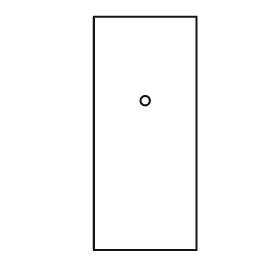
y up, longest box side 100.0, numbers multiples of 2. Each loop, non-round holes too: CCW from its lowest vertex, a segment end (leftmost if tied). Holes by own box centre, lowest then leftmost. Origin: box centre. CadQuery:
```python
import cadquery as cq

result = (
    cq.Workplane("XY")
    .moveTo(-22.0, -50.0)
    .lineTo(22.0, -50.0)
    .lineTo(22.0, 50.0)
    .lineTo(-22.0, 50.0)
    .close()
    .moveTo(0.0, 14.0)
    .circle(2.0)
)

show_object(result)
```